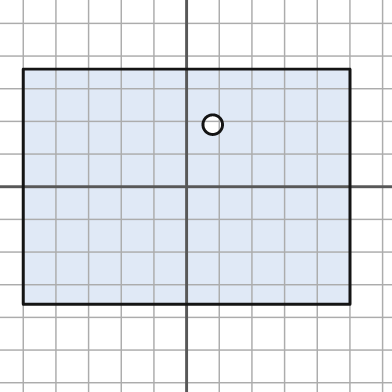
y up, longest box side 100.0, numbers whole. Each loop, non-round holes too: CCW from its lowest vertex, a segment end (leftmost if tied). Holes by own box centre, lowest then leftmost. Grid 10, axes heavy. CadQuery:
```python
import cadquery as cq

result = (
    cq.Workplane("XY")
    .moveTo(-50.0, -36.0)
    .lineTo(50.0, -36.0)
    .lineTo(50.0, 36.0)
    .lineTo(-50.0, 36.0)
    .close()
    .moveTo(8.0, 19.0)
    .circle(3.0)
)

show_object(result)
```